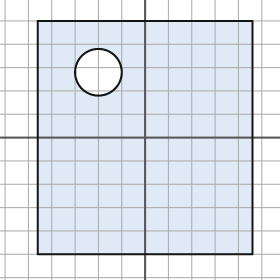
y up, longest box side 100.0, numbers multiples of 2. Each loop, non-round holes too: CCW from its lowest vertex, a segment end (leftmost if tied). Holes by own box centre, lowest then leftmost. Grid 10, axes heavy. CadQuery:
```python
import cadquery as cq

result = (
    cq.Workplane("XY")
    .moveTo(-46.0, -50.0)
    .lineTo(46.0, -50.0)
    .lineTo(46.0, 50.0)
    .lineTo(-46.0, 50.0)
    .close()
    .moveTo(-20.0, 28.0)
    .circle(10.0)
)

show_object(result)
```